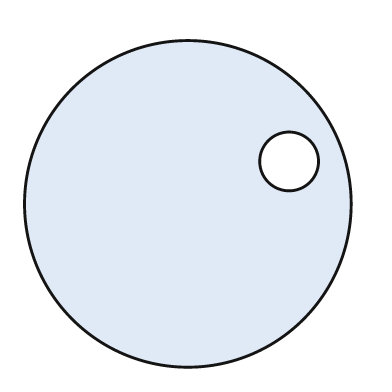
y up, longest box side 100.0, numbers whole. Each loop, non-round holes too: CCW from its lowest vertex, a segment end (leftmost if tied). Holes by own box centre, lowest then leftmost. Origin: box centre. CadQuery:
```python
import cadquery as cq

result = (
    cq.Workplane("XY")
    .moveTo(0.0, 0.0)
    .circle(50.0)
    .moveTo(31.0, 13.0)
    .circle(9.0)
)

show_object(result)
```